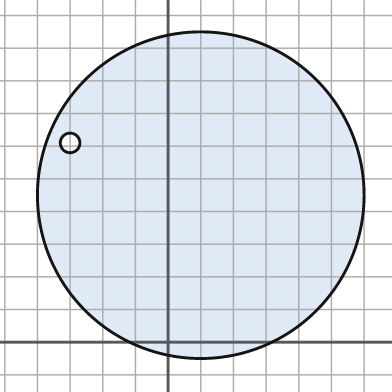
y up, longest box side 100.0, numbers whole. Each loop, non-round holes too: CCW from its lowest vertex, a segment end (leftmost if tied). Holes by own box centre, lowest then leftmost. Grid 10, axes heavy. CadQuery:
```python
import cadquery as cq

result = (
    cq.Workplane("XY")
    .moveTo(10.0, 45.0)
    .circle(50.0)
    .moveTo(-30.0, 61.0)
    .circle(3.0)
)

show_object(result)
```